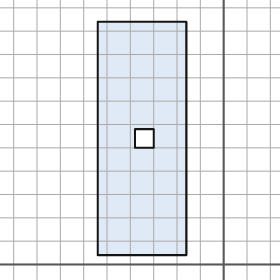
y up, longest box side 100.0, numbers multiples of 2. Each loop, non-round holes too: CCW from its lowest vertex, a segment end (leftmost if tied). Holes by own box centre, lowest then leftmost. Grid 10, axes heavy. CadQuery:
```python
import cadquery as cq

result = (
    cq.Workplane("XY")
    .moveTo(-54.0, 4.0)
    .lineTo(-16.0, 4.0)
    .lineTo(-16.0, 104.0)
    .lineTo(-54.0, 104.0)
    .close()
    .moveTo(-38.0, 50.0)
    .lineTo(-30.0, 50.0)
    .lineTo(-30.0, 58.0)
    .lineTo(-38.0, 58.0)
    .close()
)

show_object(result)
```